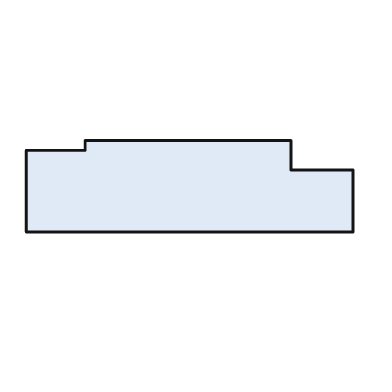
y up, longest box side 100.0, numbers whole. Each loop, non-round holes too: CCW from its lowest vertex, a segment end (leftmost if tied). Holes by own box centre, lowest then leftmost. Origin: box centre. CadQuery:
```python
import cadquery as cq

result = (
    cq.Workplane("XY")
    .moveTo(-50.0, -14.0)
    .lineTo(50.0, -14.0)
    .lineTo(50.0, 5.0)
    .lineTo(31.0, 5.0)
    .lineTo(31.0, 14.0)
    .lineTo(-32.0, 14.0)
    .lineTo(-32.0, 11.0)
    .lineTo(-50.0, 11.0)
    .close()
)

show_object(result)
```